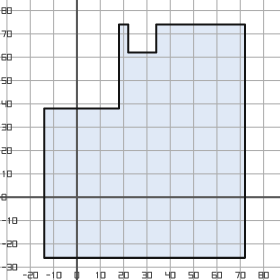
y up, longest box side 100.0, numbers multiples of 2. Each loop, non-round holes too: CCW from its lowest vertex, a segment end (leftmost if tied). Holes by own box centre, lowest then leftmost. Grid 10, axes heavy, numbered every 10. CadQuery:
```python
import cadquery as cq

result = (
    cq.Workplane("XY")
    .moveTo(-14.0, -26.0)
    .lineTo(72.0, -26.0)
    .lineTo(72.0, 74.0)
    .lineTo(34.0, 74.0)
    .lineTo(34.0, 62.0)
    .lineTo(22.0, 62.0)
    .lineTo(22.0, 74.0)
    .lineTo(18.0, 74.0)
    .lineTo(18.0, 38.0)
    .lineTo(-14.0, 38.0)
    .close()
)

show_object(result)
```